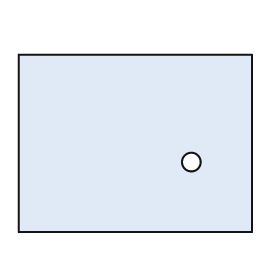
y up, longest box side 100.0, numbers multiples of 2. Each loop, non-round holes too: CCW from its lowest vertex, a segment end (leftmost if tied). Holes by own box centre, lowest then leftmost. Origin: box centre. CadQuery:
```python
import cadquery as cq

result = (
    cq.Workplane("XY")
    .moveTo(-50.0, -38.0)
    .lineTo(50.0, -38.0)
    .lineTo(50.0, 38.0)
    .lineTo(-50.0, 38.0)
    .close()
    .moveTo(24.0, -8.0)
    .circle(4.0)
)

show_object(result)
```